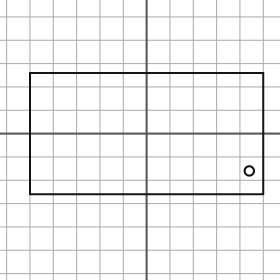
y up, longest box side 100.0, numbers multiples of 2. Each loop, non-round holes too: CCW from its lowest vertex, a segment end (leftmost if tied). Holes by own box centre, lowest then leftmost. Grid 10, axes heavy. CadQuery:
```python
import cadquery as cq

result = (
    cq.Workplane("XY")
    .moveTo(-50.0, -26.0)
    .lineTo(50.0, -26.0)
    .lineTo(50.0, 26.0)
    .lineTo(-50.0, 26.0)
    .close()
    .moveTo(44.0, -16.0)
    .circle(2.0)
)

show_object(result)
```